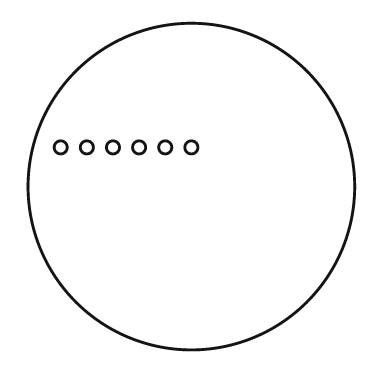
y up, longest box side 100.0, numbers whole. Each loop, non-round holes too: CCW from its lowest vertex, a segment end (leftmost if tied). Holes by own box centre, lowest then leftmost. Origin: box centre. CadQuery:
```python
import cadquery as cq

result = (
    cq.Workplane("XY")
    .moveTo(0.0, 0.0)
    .circle(50.0)
    .moveTo(-40.0, 12.0)
    .circle(2.0)
    .moveTo(-32.0, 12.0)
    .circle(2.0)
    .moveTo(-24.0, 12.0)
    .circle(2.0)
    .moveTo(-16.0, 12.0)
    .circle(2.0)
    .moveTo(-8.0, 12.0)
    .circle(2.0)
    .moveTo(0.0, 12.0)
    .circle(2.0)
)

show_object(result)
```